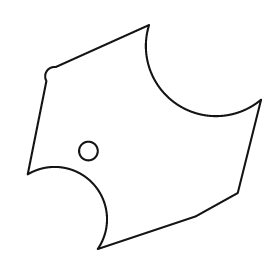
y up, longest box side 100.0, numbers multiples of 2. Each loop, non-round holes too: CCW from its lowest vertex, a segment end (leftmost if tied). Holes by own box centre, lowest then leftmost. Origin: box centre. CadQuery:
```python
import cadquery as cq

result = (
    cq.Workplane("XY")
    .moveTo(-20.0, -48.0)
    .lineTo(22.0, -34.0)
    .lineTo(40.0, -24.0)
    .lineTo(50.0, 16.0)
    .threePointArc((14.0, 14.0), (2.0, 48.0))
    .lineTo(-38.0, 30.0)
    .threePointArc((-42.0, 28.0), (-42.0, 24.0))
    .lineTo(-50.0, -16.0)
    .threePointArc((-22.0, -20.0), (-20.0, -48.0))
    .close()
    .moveTo(-24.0, -6.0)
    .circle(4.0)
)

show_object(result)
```